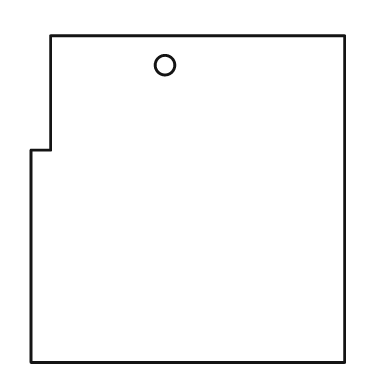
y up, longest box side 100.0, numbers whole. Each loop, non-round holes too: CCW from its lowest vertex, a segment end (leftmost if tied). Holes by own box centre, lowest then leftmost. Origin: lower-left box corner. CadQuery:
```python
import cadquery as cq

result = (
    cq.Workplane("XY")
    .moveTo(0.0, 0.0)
    .lineTo(96.0, 0.0)
    .lineTo(96.0, 100.0)
    .lineTo(6.0, 100.0)
    .lineTo(6.0, 65.0)
    .lineTo(0.0, 65.0)
    .close()
    .moveTo(41.0, 91.0)
    .circle(3.0)
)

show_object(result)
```